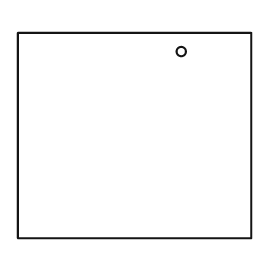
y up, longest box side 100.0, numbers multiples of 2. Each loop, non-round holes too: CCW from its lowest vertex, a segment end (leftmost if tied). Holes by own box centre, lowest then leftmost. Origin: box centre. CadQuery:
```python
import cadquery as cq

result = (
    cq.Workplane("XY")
    .moveTo(-50.0, -44.0)
    .lineTo(50.0, -44.0)
    .lineTo(50.0, 44.0)
    .lineTo(-50.0, 44.0)
    .close()
    .moveTo(20.0, 36.0)
    .circle(2.0)
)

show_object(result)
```